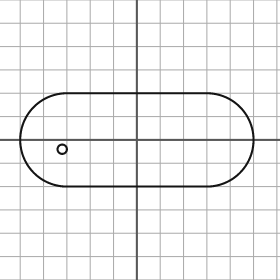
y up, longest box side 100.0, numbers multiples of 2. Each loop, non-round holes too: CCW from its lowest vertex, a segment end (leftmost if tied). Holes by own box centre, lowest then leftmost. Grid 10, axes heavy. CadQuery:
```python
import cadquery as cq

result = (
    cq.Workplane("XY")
    .moveTo(-30.0, -20.0)
    .lineTo(30.0, -20.0)
    .threePointArc((50.0, 0.0), (30.0, 20.0))
    .lineTo(-30.0, 20.0)
    .threePointArc((-50.0, 0.0), (-30.0, -20.0))
    .close()
    .moveTo(-32.0, -4.0)
    .circle(2.0)
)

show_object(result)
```